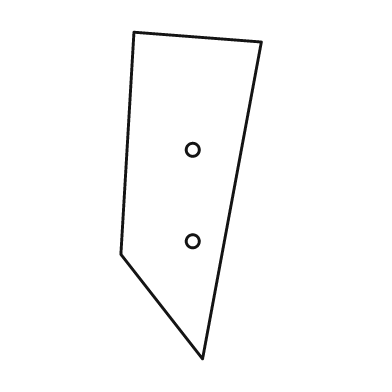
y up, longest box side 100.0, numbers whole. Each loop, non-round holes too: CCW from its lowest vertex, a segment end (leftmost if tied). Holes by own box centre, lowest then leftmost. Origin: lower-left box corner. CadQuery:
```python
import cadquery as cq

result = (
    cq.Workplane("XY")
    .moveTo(25.0, 0.0)
    .lineTo(43.0, 97.0)
    .lineTo(4.0, 100.0)
    .lineTo(0.0, 32.0)
    .close()
    .moveTo(22.0, 36.0)
    .circle(2.0)
    .moveTo(22.0, 64.0)
    .circle(2.0)
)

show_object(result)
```